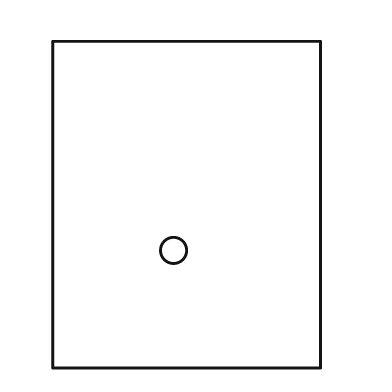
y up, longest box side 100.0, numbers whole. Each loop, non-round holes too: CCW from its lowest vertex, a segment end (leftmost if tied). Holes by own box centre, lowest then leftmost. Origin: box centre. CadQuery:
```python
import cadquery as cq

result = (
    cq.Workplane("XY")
    .moveTo(-41.0, -50.0)
    .lineTo(41.0, -50.0)
    .lineTo(41.0, 50.0)
    .lineTo(-41.0, 50.0)
    .close()
    .moveTo(-4.0, -14.0)
    .circle(4.0)
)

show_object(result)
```